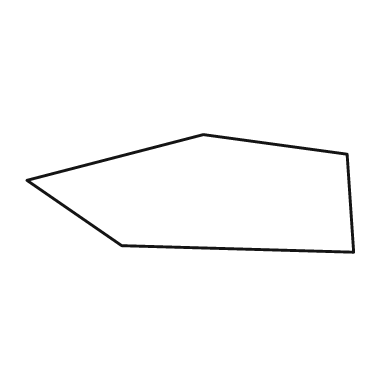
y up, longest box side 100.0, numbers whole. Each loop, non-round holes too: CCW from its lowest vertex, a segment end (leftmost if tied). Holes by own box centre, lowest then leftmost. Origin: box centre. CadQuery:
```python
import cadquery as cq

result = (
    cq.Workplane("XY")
    .moveTo(50.0, -18.0)
    .lineTo(48.0, 12.0)
    .lineTo(4.0, 18.0)
    .lineTo(-50.0, 4.0)
    .lineTo(-21.0, -16.0)
    .close()
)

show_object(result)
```